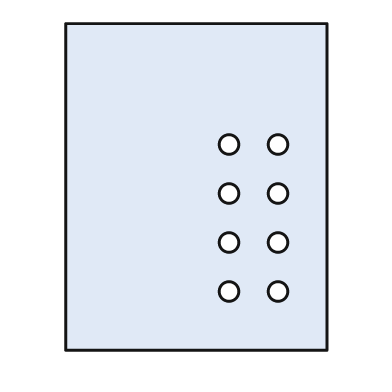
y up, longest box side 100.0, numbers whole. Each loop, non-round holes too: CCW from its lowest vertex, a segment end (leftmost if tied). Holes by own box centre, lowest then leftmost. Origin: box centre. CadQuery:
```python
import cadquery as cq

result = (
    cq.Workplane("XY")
    .moveTo(-40.0, -50.0)
    .lineTo(40.0, -50.0)
    .lineTo(40.0, 50.0)
    .lineTo(-40.0, 50.0)
    .close()
    .moveTo(10.0, -32.0)
    .circle(3.0)
    .moveTo(25.0, -32.0)
    .circle(3.0)
    .moveTo(10.0, -17.0)
    .circle(3.0)
    .moveTo(25.0, -17.0)
    .circle(3.0)
    .moveTo(10.0, -2.0)
    .circle(3.0)
    .moveTo(25.0, -2.0)
    .circle(3.0)
    .moveTo(10.0, 13.0)
    .circle(3.0)
    .moveTo(25.0, 13.0)
    .circle(3.0)
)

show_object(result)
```